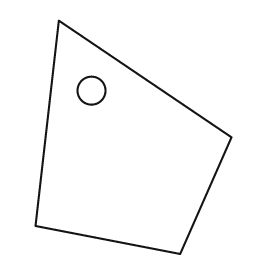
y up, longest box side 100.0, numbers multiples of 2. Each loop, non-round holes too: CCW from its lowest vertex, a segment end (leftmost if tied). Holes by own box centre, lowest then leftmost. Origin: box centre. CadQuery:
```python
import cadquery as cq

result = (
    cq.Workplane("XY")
    .moveTo(20.0, -50.0)
    .lineTo(42.0, 0.0)
    .lineTo(-32.0, 50.0)
    .lineTo(-42.0, -38.0)
    .close()
    .moveTo(-18.0, 20.0)
    .circle(6.0)
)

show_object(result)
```